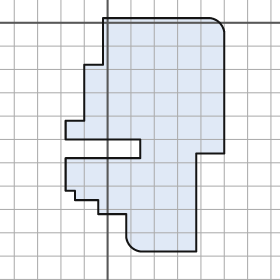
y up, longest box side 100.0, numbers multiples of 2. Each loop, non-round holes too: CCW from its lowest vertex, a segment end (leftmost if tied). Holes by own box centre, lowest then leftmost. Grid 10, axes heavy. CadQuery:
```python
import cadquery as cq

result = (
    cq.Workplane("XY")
    .moveTo(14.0, -98.0)
    .lineTo(38.0, -98.0)
    .lineTo(38.0, -56.0)
    .lineTo(50.0, -56.0)
    .lineTo(50.0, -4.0)
    .threePointArc((48.0, 0.0), (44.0, 2.0))
    .lineTo(-2.0, 2.0)
    .lineTo(-2.0, -18.0)
    .lineTo(-10.0, -18.0)
    .lineTo(-10.0, -42.0)
    .lineTo(-18.0, -42.0)
    .lineTo(-18.0, -50.0)
    .lineTo(14.0, -50.0)
    .lineTo(14.0, -58.0)
    .lineTo(-18.0, -58.0)
    .lineTo(-18.0, -72.0)
    .lineTo(-14.0, -72.0)
    .lineTo(-14.0, -76.0)
    .lineTo(-4.0, -76.0)
    .lineTo(-4.0, -82.0)
    .lineTo(8.0, -82.0)
    .lineTo(8.0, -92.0)
    .threePointArc((10.0, -96.0), (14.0, -98.0))
    .close()
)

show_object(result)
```